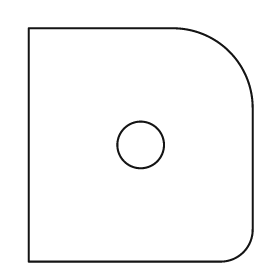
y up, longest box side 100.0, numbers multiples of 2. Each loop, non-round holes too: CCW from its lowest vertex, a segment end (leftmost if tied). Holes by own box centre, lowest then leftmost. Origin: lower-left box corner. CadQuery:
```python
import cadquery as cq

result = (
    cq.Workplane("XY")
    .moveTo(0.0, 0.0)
    .lineTo(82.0, 0.0)
    .threePointArc((92.0, 4.0), (96.0, 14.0))
    .lineTo(96.0, 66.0)
    .threePointArc((86.0, 90.0), (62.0, 100.0))
    .lineTo(0.0, 100.0)
    .close()
    .moveTo(48.0, 50.0)
    .circle(10.0)
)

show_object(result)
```